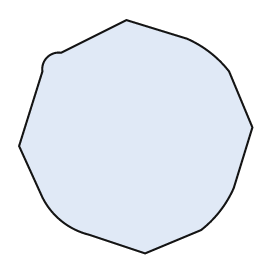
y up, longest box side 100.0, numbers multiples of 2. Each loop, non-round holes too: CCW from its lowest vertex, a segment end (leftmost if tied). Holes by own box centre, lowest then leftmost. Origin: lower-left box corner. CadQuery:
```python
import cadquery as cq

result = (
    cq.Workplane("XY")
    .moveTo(54.0, 0.0)
    .lineTo(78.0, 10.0)
    .threePointArc((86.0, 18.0), (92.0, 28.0))
    .lineTo(100.0, 54.0)
    .lineTo(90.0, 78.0)
    .threePointArc((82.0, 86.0), (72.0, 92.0))
    .lineTo(46.0, 100.0)
    .lineTo(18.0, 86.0)
    .threePointArc((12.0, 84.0), (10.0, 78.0))
    .lineTo(0.0, 46.0)
    .lineTo(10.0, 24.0)
    .threePointArc((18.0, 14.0), (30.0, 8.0))
    .close()
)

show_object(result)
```